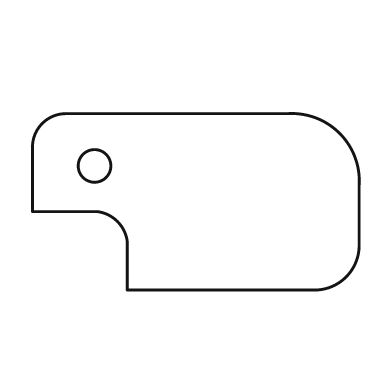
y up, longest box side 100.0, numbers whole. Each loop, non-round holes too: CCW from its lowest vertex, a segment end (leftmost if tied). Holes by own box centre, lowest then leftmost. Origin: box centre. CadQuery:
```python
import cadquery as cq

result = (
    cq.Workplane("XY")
    .moveTo(-21.0, -27.0)
    .lineTo(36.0, -27.0)
    .threePointArc((46.0, -23.0), (50.0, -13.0))
    .lineTo(50.0, 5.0)
    .threePointArc((44.0, 21.0), (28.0, 27.0))
    .lineTo(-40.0, 27.0)
    .threePointArc((-47.0, 24.0), (-50.0, 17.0))
    .lineTo(-50.0, -3.0)
    .lineTo(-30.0, -3.0)
    .threePointArc((-24.0, -6.0), (-21.0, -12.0))
    .close()
    .moveTo(-31.0, 11.0)
    .circle(5.0)
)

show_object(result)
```